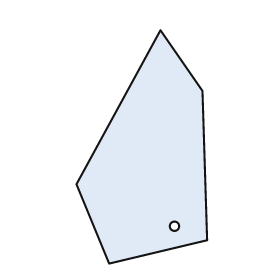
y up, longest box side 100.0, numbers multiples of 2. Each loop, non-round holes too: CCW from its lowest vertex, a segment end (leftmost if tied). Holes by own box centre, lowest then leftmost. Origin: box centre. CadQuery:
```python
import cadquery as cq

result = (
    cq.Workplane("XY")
    .moveTo(-14.0, -50.0)
    .lineTo(28.0, -40.0)
    .lineTo(26.0, 24.0)
    .lineTo(8.0, 50.0)
    .lineTo(-28.0, -16.0)
    .close()
    .moveTo(14.0, -34.0)
    .circle(2.0)
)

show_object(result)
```